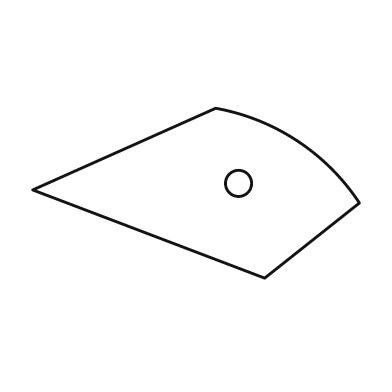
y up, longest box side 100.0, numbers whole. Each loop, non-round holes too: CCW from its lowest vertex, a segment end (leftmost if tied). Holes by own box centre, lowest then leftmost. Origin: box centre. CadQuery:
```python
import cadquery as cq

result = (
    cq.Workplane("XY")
    .moveTo(21.0, -26.0)
    .lineTo(50.0, -3.0)
    .threePointArc((31.0, 16.0), (6.0, 26.0))
    .lineTo(-50.0, 1.0)
    .close()
    .moveTo(13.0, 3.0)
    .circle(4.0)
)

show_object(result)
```